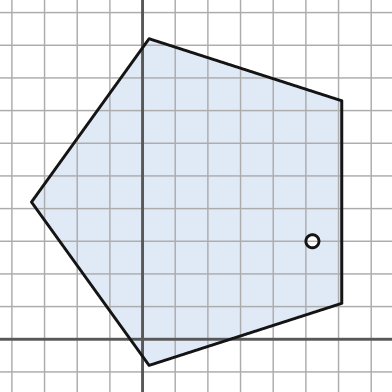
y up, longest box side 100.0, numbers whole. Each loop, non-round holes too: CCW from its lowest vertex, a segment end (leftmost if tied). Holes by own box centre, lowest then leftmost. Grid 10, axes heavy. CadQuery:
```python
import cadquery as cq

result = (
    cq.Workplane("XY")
    .moveTo(2.0, -8.0)
    .lineTo(61.0, 11.0)
    .lineTo(61.0, 73.0)
    .lineTo(2.0, 92.0)
    .lineTo(-34.0, 42.0)
    .close()
    .moveTo(52.0, 30.0)
    .circle(2.0)
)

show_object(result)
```